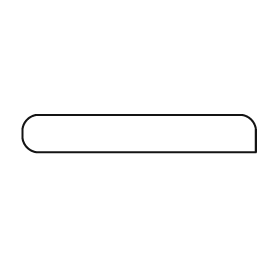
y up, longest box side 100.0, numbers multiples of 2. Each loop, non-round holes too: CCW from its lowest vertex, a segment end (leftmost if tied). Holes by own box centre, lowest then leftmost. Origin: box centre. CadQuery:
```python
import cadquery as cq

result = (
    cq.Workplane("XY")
    .moveTo(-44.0, -8.0)
    .lineTo(50.0, -8.0)
    .lineTo(50.0, 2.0)
    .threePointArc((48.0, 6.0), (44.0, 8.0))
    .lineTo(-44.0, 8.0)
    .threePointArc((-48.0, 6.0), (-50.0, 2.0))
    .lineTo(-50.0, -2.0)
    .threePointArc((-48.0, -6.0), (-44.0, -8.0))
    .close()
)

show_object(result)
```